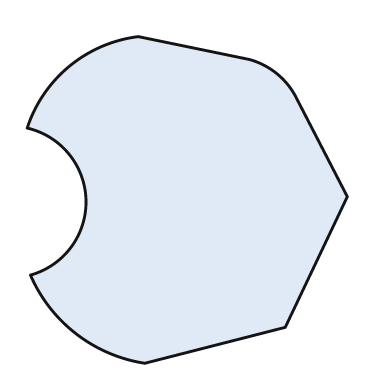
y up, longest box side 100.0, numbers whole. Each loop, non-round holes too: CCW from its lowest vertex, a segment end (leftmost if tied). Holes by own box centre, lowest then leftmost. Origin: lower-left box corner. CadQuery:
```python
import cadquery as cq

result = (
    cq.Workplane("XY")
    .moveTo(36.0, 0.0)
    .lineTo(79.0, 11.0)
    .lineTo(98.0, 51.0)
    .lineTo(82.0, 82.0)
    .threePointArc((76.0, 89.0), (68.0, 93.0))
    .lineTo(34.0, 100.0)
    .threePointArc((13.0, 91.0), (0.0, 72.0))
    .threePointArc((18.0, 50.0), (1.0, 27.0))
    .threePointArc((15.0, 9.0), (36.0, 0.0))
    .close()
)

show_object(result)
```